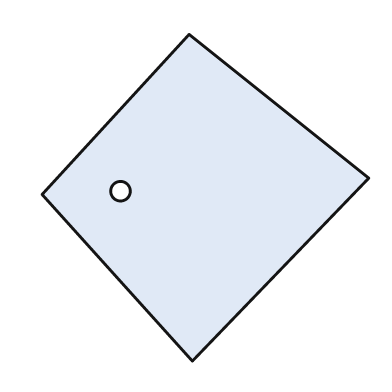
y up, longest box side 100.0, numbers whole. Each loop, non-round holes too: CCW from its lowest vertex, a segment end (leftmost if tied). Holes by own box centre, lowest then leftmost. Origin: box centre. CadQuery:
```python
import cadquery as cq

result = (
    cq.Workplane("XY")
    .moveTo(-4.0, -50.0)
    .lineTo(50.0, 6.0)
    .lineTo(-5.0, 50.0)
    .lineTo(-50.0, 1.0)
    .close()
    .moveTo(-26.0, 2.0)
    .circle(3.0)
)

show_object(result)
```